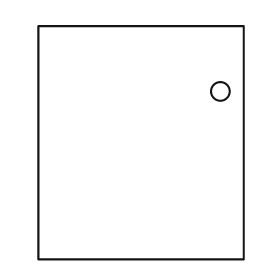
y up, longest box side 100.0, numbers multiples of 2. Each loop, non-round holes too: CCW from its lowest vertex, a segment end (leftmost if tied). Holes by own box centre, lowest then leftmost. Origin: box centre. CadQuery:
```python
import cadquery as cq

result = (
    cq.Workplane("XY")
    .moveTo(-44.0, -50.0)
    .lineTo(44.0, -50.0)
    .lineTo(44.0, 50.0)
    .lineTo(-44.0, 50.0)
    .close()
    .moveTo(34.0, 22.0)
    .circle(4.0)
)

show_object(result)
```